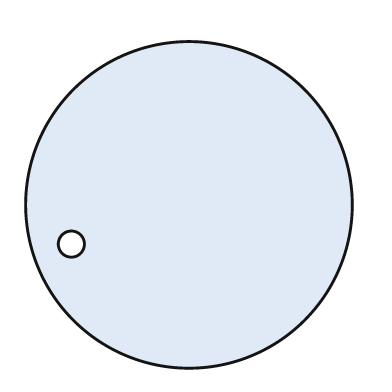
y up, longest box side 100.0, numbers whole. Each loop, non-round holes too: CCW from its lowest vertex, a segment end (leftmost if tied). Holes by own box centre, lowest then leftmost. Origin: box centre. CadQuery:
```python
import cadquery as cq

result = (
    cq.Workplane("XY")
    .moveTo(0.0, 0.0)
    .circle(50.0)
    .moveTo(-36.0, -12.0)
    .circle(4.0)
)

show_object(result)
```